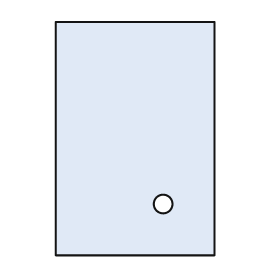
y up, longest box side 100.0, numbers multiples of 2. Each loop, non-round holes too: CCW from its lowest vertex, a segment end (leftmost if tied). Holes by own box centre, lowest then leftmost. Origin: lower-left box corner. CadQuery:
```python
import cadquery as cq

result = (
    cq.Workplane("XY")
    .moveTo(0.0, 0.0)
    .lineTo(68.0, 0.0)
    .lineTo(68.0, 100.0)
    .lineTo(0.0, 100.0)
    .close()
    .moveTo(46.0, 22.0)
    .circle(4.0)
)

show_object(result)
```